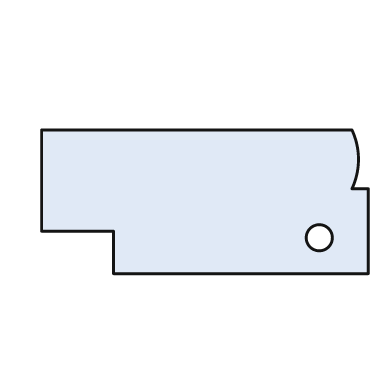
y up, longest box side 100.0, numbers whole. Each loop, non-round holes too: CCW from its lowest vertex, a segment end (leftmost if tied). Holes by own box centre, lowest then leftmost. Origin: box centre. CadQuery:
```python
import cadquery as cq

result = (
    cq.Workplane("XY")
    .moveTo(-28.0, -22.0)
    .lineTo(50.0, -22.0)
    .lineTo(50.0, 4.0)
    .lineTo(45.0, 4.0)
    .threePointArc((47.0, 13.0), (45.0, 22.0))
    .lineTo(-50.0, 22.0)
    .lineTo(-50.0, -9.0)
    .lineTo(-28.0, -9.0)
    .close()
    .moveTo(35.0, -11.0)
    .circle(4.0)
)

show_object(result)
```